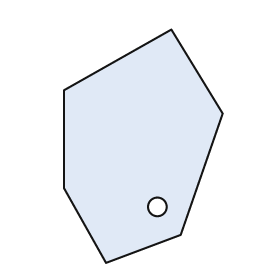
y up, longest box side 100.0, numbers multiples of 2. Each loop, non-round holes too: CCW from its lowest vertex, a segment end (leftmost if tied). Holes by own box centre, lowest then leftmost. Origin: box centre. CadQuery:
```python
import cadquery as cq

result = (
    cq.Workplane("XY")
    .moveTo(-16.0, -50.0)
    .lineTo(16.0, -38.0)
    .lineTo(34.0, 14.0)
    .lineTo(12.0, 50.0)
    .lineTo(-34.0, 24.0)
    .lineTo(-34.0, -18.0)
    .close()
    .moveTo(6.0, -26.0)
    .circle(4.0)
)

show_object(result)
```